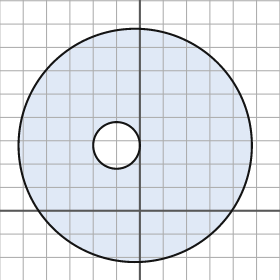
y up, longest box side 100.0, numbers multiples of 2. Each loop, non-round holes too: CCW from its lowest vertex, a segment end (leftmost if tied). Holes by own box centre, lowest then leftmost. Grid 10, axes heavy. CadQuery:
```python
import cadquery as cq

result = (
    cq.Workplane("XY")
    .moveTo(-2.0, 28.0)
    .circle(50.0)
    .moveTo(-10.0, 28.0)
    .circle(10.0)
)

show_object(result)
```